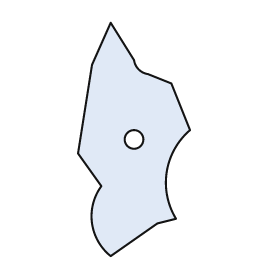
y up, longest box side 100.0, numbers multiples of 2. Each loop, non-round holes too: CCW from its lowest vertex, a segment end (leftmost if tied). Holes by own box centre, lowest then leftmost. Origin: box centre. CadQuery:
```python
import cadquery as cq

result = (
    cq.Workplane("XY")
    .moveTo(-10.0, -50.0)
    .lineTo(10.0, -36.0)
    .lineTo(18.0, -34.0)
    .threePointArc((14.0, -14.0), (24.0, 4.0))
    .lineTo(16.0, 24.0)
    .lineTo(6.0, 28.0)
    .threePointArc((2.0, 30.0), (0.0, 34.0))
    .lineTo(-10.0, 50.0)
    .lineTo(-18.0, 32.0)
    .lineTo(-24.0, -6.0)
    .lineTo(-14.0, -20.0)
    .threePointArc((-18.0, -36.0), (-10.0, -50.0))
    .close()
    .moveTo(0.0, 0.0)
    .circle(4.0)
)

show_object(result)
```